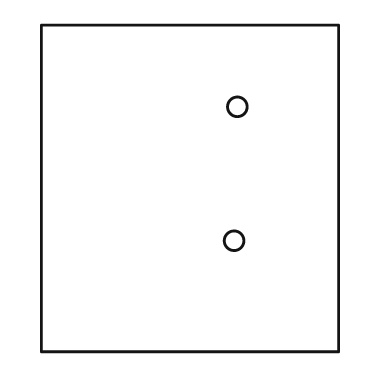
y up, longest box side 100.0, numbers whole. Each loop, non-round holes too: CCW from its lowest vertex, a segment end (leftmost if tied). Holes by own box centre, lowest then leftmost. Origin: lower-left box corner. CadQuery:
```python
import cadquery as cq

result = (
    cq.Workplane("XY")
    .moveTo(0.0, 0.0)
    .lineTo(91.0, 0.0)
    .lineTo(91.0, 100.0)
    .lineTo(0.0, 100.0)
    .close()
    .moveTo(59.0, 34.0)
    .circle(3.0)
    .moveTo(60.0, 75.0)
    .circle(3.0)
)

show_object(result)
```